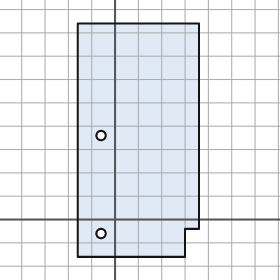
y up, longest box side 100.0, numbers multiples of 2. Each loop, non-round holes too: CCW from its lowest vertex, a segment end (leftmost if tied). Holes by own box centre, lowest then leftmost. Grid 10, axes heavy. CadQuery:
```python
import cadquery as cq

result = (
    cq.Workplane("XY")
    .moveTo(-16.0, -16.0)
    .lineTo(30.0, -16.0)
    .lineTo(30.0, -4.0)
    .lineTo(36.0, -4.0)
    .lineTo(36.0, 84.0)
    .lineTo(-16.0, 84.0)
    .close()
    .moveTo(-6.0, -6.0)
    .circle(2.0)
    .moveTo(-6.0, 36.0)
    .circle(2.0)
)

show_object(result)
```